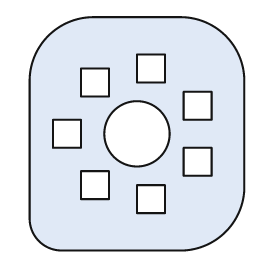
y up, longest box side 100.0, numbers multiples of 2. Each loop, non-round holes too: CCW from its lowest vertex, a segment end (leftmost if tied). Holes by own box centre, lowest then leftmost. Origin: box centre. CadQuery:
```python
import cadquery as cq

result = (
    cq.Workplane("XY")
    .moveTo(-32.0, -50.0)
    .lineTo(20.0, -50.0)
    .threePointArc((38.0, -42.0), (46.0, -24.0))
    .lineTo(46.0, 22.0)
    .threePointArc((38.0, 42.0), (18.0, 50.0))
    .lineTo(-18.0, 50.0)
    .threePointArc((-38.0, 42.0), (-46.0, 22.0))
    .lineTo(-46.0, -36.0)
    .threePointArc((-42.0, -46.0), (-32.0, -50.0))
    .close()
    .moveTo(0.0, -34.0)
    .lineTo(12.0, -34.0)
    .lineTo(12.0, -22.0)
    .lineTo(0.0, -22.0)
    .close()
    .moveTo(-24.0, -28.0)
    .lineTo(-12.0, -28.0)
    .lineTo(-12.0, -16.0)
    .lineTo(-24.0, -16.0)
    .close()
    .moveTo(20.0, -18.0)
    .lineTo(32.0, -18.0)
    .lineTo(32.0, -6.0)
    .lineTo(20.0, -6.0)
    .close()
    .moveTo(-36.0, -6.0)
    .lineTo(-24.0, -6.0)
    .lineTo(-24.0, 6.0)
    .lineTo(-36.0, 6.0)
    .close()
    .moveTo(0.0, 0.0)
    .circle(14.0)
    .moveTo(20.0, 6.0)
    .lineTo(32.0, 6.0)
    .lineTo(32.0, 18.0)
    .lineTo(20.0, 18.0)
    .close()
    .moveTo(-24.0, 16.0)
    .lineTo(-12.0, 16.0)
    .lineTo(-12.0, 28.0)
    .lineTo(-24.0, 28.0)
    .close()
    .moveTo(0.0, 22.0)
    .lineTo(12.0, 22.0)
    .lineTo(12.0, 34.0)
    .lineTo(0.0, 34.0)
    .close()
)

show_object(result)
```